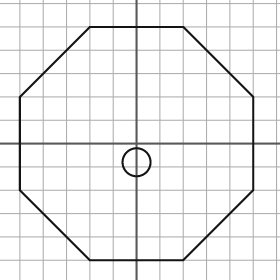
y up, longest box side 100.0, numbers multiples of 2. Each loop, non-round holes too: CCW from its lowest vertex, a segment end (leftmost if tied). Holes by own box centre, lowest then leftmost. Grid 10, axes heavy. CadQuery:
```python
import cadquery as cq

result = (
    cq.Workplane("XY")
    .moveTo(-20.0, -50.0)
    .lineTo(20.0, -50.0)
    .lineTo(50.0, -20.0)
    .lineTo(50.0, 20.0)
    .lineTo(20.0, 50.0)
    .lineTo(-20.0, 50.0)
    .lineTo(-50.0, 20.0)
    .lineTo(-50.0, -20.0)
    .close()
    .moveTo(0.0, -8.0)
    .circle(6.0)
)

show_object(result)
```